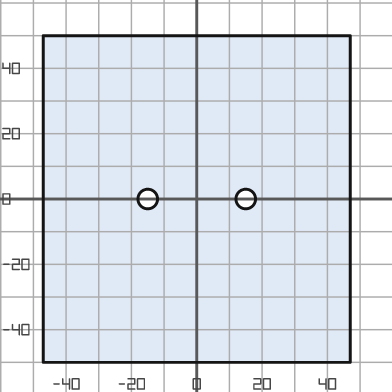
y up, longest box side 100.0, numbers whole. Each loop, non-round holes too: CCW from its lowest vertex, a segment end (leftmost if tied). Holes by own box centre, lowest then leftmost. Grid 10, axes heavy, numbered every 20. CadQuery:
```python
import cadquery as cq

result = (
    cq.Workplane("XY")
    .moveTo(-47.0, -50.0)
    .lineTo(47.0, -50.0)
    .lineTo(47.0, 50.0)
    .lineTo(-47.0, 50.0)
    .close()
    .moveTo(-15.0, 0.0)
    .circle(3.0)
    .moveTo(15.0, 0.0)
    .circle(3.0)
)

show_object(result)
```